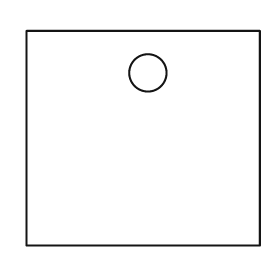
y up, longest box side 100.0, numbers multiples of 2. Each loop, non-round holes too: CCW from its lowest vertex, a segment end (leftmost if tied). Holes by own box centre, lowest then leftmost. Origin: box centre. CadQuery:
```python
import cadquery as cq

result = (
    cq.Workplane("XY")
    .moveTo(-50.0, -46.0)
    .lineTo(50.0, -46.0)
    .lineTo(50.0, 46.0)
    .lineTo(-50.0, 46.0)
    .close()
    .moveTo(2.0, 28.0)
    .circle(8.0)
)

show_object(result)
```